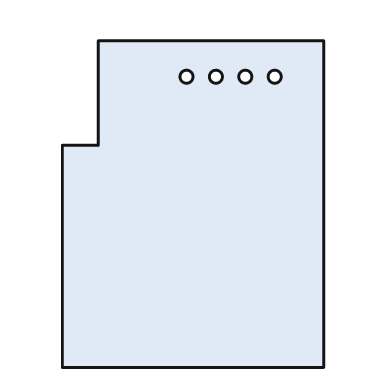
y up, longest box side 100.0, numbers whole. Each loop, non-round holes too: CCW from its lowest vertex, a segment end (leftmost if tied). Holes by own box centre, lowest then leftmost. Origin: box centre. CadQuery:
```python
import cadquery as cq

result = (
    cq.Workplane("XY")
    .moveTo(-40.0, -50.0)
    .lineTo(40.0, -50.0)
    .lineTo(40.0, 50.0)
    .lineTo(-29.0, 50.0)
    .lineTo(-29.0, 18.0)
    .lineTo(-40.0, 18.0)
    .close()
    .moveTo(-2.0, 39.0)
    .circle(2.0)
    .moveTo(7.0, 39.0)
    .circle(2.0)
    .moveTo(16.0, 39.0)
    .circle(2.0)
    .moveTo(25.0, 39.0)
    .circle(2.0)
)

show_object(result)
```